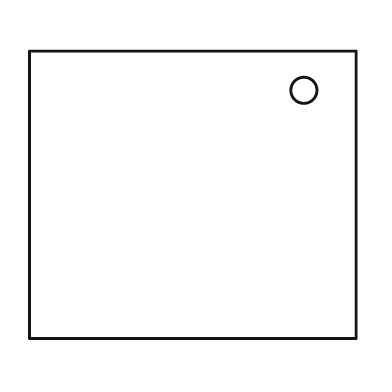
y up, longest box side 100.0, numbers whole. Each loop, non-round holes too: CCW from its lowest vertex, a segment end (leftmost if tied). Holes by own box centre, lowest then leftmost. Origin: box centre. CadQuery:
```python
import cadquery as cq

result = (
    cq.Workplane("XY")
    .moveTo(-50.0, -44.0)
    .lineTo(50.0, -44.0)
    .lineTo(50.0, 44.0)
    .lineTo(-50.0, 44.0)
    .close()
    .moveTo(34.0, 32.0)
    .circle(4.0)
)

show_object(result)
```